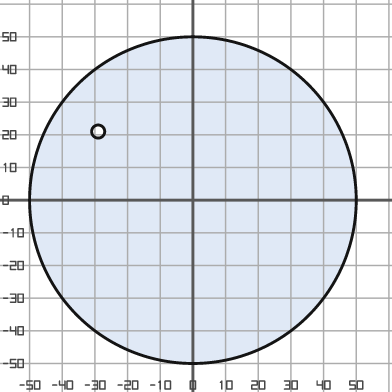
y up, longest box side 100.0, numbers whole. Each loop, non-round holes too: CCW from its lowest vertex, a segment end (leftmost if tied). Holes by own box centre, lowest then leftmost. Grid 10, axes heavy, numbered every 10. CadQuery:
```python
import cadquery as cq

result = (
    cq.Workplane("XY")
    .moveTo(0.0, 0.0)
    .circle(50.0)
    .moveTo(-29.0, 21.0)
    .circle(2.0)
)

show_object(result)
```